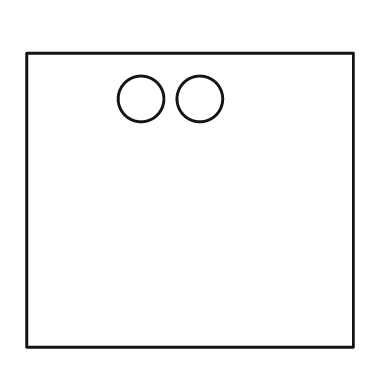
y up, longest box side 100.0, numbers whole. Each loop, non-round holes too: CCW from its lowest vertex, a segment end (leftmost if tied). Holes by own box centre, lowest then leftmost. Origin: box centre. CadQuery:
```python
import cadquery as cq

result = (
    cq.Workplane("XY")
    .moveTo(-50.0, -45.0)
    .lineTo(50.0, -45.0)
    .lineTo(50.0, 45.0)
    .lineTo(-50.0, 45.0)
    .close()
    .moveTo(-15.0, 31.0)
    .circle(7.0)
    .moveTo(3.0, 31.0)
    .circle(7.0)
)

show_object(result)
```